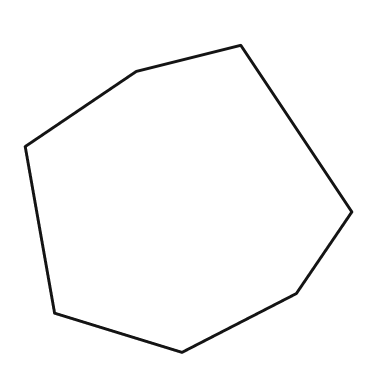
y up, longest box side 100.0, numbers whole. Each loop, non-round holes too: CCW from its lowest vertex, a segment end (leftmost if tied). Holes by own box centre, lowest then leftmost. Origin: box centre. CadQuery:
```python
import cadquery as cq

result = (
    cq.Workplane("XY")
    .moveTo(-2.0, -47.0)
    .lineTo(33.0, -29.0)
    .lineTo(50.0, -4.0)
    .lineTo(16.0, 47.0)
    .lineTo(-16.0, 39.0)
    .lineTo(-50.0, 16.0)
    .lineTo(-41.0, -35.0)
    .close()
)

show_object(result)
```